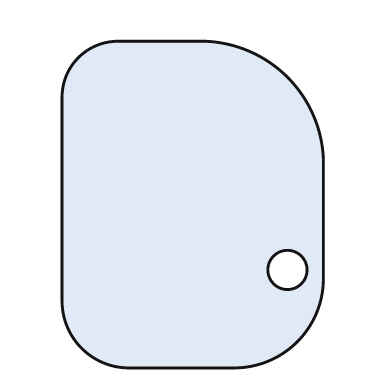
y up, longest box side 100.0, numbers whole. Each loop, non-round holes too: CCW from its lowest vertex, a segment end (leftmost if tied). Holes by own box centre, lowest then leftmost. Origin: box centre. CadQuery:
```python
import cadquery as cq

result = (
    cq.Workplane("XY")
    .moveTo(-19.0, -50.0)
    .lineTo(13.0, -50.0)
    .threePointArc((32.0, -42.0), (40.0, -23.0))
    .lineTo(40.0, 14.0)
    .threePointArc((29.0, 39.0), (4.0, 50.0))
    .lineTo(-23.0, 50.0)
    .threePointArc((-35.0, 45.0), (-40.0, 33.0))
    .lineTo(-40.0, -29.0)
    .threePointArc((-34.0, -44.0), (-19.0, -50.0))
    .close()
    .moveTo(29.0, -20.0)
    .circle(6.0)
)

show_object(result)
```